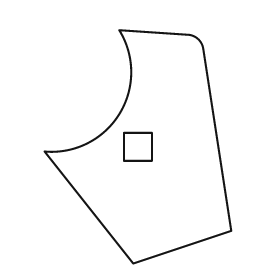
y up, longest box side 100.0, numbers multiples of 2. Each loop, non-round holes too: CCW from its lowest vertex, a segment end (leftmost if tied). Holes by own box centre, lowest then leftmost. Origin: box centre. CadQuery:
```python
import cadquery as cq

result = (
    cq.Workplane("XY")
    .moveTo(-2.0, -50.0)
    .lineTo(40.0, -36.0)
    .lineTo(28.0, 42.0)
    .threePointArc((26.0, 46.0), (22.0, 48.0))
    .lineTo(-8.0, 50.0)
    .threePointArc((-8.0, 14.0), (-40.0, -2.0))
    .close()
    .moveTo(-6.0, -6.0)
    .lineTo(6.0, -6.0)
    .lineTo(6.0, 6.0)
    .lineTo(-6.0, 6.0)
    .close()
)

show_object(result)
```